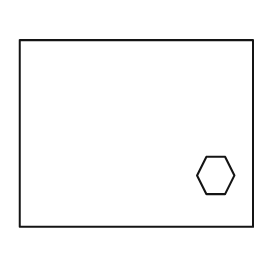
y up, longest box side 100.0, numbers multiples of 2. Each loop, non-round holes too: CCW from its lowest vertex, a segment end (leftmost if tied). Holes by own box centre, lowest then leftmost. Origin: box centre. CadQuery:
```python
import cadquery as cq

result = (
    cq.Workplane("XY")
    .moveTo(-50.0, -40.0)
    .lineTo(50.0, -40.0)
    .lineTo(50.0, 40.0)
    .lineTo(-50.0, 40.0)
    .close()
    .moveTo(30.0, -26.0)
    .lineTo(38.0, -26.0)
    .lineTo(42.0, -18.0)
    .lineTo(38.0, -10.0)
    .lineTo(30.0, -10.0)
    .lineTo(26.0, -18.0)
    .close()
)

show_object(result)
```